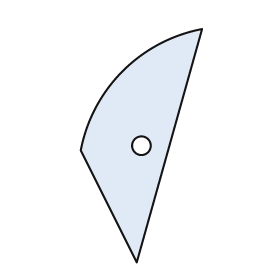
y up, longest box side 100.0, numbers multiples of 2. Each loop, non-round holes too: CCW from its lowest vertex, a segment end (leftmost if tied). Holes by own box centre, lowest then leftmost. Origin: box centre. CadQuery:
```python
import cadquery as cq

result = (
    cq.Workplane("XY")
    .moveTo(-2.0, -50.0)
    .lineTo(26.0, 50.0)
    .threePointArc((-8.0, 32.0), (-26.0, -2.0))
    .close()
    .moveTo(0.0, 0.0)
    .circle(4.0)
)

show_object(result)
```